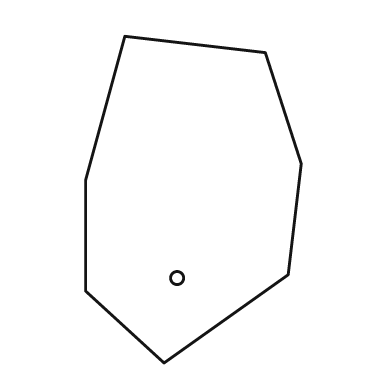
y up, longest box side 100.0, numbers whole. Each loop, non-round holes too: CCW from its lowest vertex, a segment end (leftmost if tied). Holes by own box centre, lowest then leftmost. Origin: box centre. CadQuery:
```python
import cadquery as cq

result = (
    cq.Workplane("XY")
    .moveTo(-9.0, -50.0)
    .lineTo(29.0, -23.0)
    .lineTo(33.0, 11.0)
    .lineTo(22.0, 45.0)
    .lineTo(-21.0, 50.0)
    .lineTo(-33.0, 6.0)
    .lineTo(-33.0, -28.0)
    .close()
    .moveTo(-5.0, -24.0)
    .circle(2.0)
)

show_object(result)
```